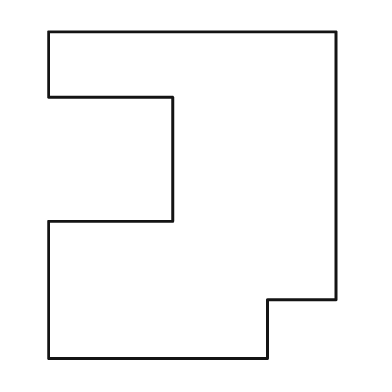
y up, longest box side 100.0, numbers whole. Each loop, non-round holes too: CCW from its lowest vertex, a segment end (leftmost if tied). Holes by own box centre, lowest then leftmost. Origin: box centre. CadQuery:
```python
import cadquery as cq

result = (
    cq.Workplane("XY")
    .moveTo(-44.0, -50.0)
    .lineTo(23.0, -50.0)
    .lineTo(23.0, -32.0)
    .lineTo(44.0, -32.0)
    .lineTo(44.0, 50.0)
    .lineTo(-44.0, 50.0)
    .lineTo(-44.0, 30.0)
    .lineTo(-6.0, 30.0)
    .lineTo(-6.0, -8.0)
    .lineTo(-44.0, -8.0)
    .close()
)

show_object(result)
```